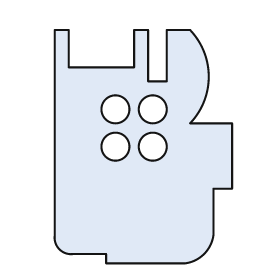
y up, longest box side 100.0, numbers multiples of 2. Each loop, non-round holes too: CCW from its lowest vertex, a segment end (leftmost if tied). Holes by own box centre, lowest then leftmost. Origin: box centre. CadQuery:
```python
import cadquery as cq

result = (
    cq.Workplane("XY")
    .moveTo(-16.0, -50.0)
    .lineTo(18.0, -50.0)
    .threePointArc((26.0, -46.0), (30.0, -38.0))
    .lineTo(30.0, -18.0)
    .lineTo(38.0, -18.0)
    .lineTo(38.0, 10.0)
    .lineTo(20.0, 10.0)
    .threePointArc((28.0, 30.0), (20.0, 50.0))
    .lineTo(10.0, 50.0)
    .lineTo(10.0, 28.0)
    .lineTo(2.0, 28.0)
    .lineTo(2.0, 50.0)
    .lineTo(-4.0, 50.0)
    .lineTo(-4.0, 34.0)
    .lineTo(-32.0, 34.0)
    .lineTo(-32.0, 50.0)
    .lineTo(-38.0, 50.0)
    .lineTo(-38.0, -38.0)
    .threePointArc((-36.0, -44.0), (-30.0, -46.0))
    .lineTo(-16.0, -46.0)
    .close()
    .moveTo(-12.0, 0.0)
    .circle(6.0)
    .moveTo(4.0, 0.0)
    .circle(6.0)
    .moveTo(-12.0, 16.0)
    .circle(6.0)
    .moveTo(4.0, 16.0)
    .circle(6.0)
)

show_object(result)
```